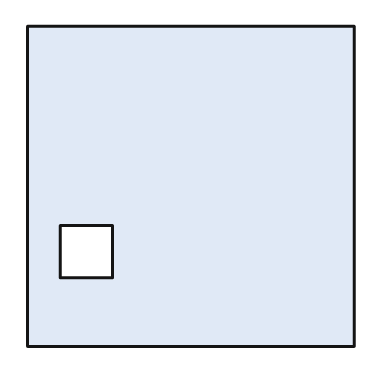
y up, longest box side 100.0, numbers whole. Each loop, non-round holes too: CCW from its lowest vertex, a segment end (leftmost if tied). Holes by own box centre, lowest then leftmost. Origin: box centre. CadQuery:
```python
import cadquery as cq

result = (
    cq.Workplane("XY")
    .moveTo(-50.0, -49.0)
    .lineTo(50.0, -49.0)
    .lineTo(50.0, 49.0)
    .lineTo(-50.0, 49.0)
    .close()
    .moveTo(-40.0, -28.0)
    .lineTo(-24.0, -28.0)
    .lineTo(-24.0, -12.0)
    .lineTo(-40.0, -12.0)
    .close()
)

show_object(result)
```